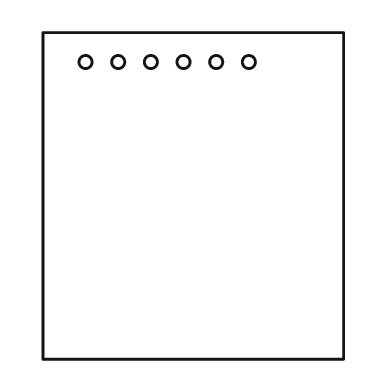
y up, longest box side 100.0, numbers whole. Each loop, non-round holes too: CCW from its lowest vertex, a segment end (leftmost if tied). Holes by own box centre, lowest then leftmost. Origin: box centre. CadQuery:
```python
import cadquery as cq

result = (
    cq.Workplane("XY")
    .moveTo(-46.0, -50.0)
    .lineTo(46.0, -50.0)
    .lineTo(46.0, 50.0)
    .lineTo(-46.0, 50.0)
    .close()
    .moveTo(-33.0, 41.0)
    .circle(2.0)
    .moveTo(-23.0, 41.0)
    .circle(2.0)
    .moveTo(-13.0, 41.0)
    .circle(2.0)
    .moveTo(-3.0, 41.0)
    .circle(2.0)
    .moveTo(7.0, 41.0)
    .circle(2.0)
    .moveTo(17.0, 41.0)
    .circle(2.0)
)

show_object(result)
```